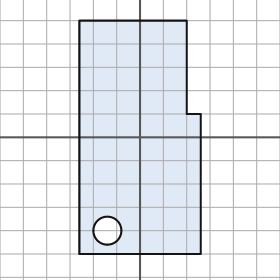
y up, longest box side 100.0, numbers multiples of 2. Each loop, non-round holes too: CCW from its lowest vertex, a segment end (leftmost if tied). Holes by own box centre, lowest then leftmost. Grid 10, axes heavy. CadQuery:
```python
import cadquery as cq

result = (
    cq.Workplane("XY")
    .moveTo(-26.0, -50.0)
    .lineTo(26.0, -50.0)
    .lineTo(26.0, 10.0)
    .lineTo(20.0, 10.0)
    .lineTo(20.0, 50.0)
    .lineTo(-26.0, 50.0)
    .close()
    .moveTo(-14.0, -40.0)
    .circle(6.0)
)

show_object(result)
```